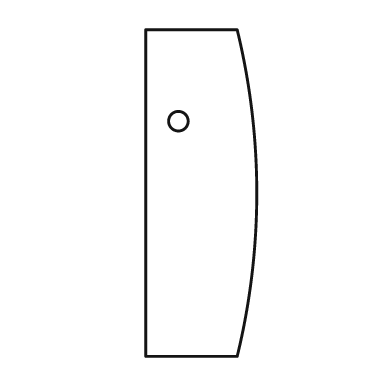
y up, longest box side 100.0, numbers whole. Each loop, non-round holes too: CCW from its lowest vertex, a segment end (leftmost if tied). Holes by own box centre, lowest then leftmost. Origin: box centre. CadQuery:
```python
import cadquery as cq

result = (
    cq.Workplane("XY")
    .moveTo(-17.0, -50.0)
    .lineTo(11.0, -50.0)
    .threePointArc((17.0, 0.0), (11.0, 50.0))
    .lineTo(-17.0, 50.0)
    .close()
    .moveTo(-7.0, 22.0)
    .circle(3.0)
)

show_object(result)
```